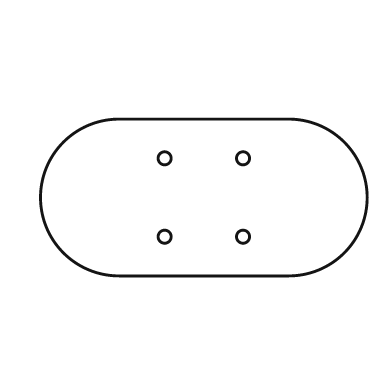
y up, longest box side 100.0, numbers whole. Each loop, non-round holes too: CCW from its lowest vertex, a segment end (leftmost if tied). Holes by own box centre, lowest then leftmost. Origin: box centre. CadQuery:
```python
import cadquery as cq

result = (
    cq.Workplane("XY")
    .moveTo(-26.0, -24.0)
    .lineTo(26.0, -24.0)
    .threePointArc((50.0, 0.0), (26.0, 24.0))
    .lineTo(-26.0, 24.0)
    .threePointArc((-50.0, 0.0), (-26.0, -24.0))
    .close()
    .moveTo(-12.0, -12.0)
    .circle(2.0)
    .moveTo(12.0, -12.0)
    .circle(2.0)
    .moveTo(-12.0, 12.0)
    .circle(2.0)
    .moveTo(12.0, 12.0)
    .circle(2.0)
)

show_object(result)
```